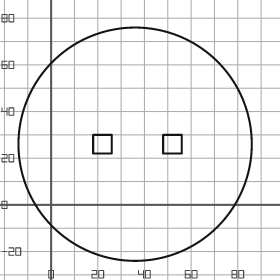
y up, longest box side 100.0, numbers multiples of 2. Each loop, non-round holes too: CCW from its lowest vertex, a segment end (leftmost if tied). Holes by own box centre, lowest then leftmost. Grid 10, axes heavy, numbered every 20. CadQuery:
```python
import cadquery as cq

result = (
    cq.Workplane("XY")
    .moveTo(36.0, 26.0)
    .circle(50.0)
    .moveTo(18.0, 22.0)
    .lineTo(26.0, 22.0)
    .lineTo(26.0, 30.0)
    .lineTo(18.0, 30.0)
    .close()
    .moveTo(48.0, 22.0)
    .lineTo(56.0, 22.0)
    .lineTo(56.0, 30.0)
    .lineTo(48.0, 30.0)
    .close()
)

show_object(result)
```